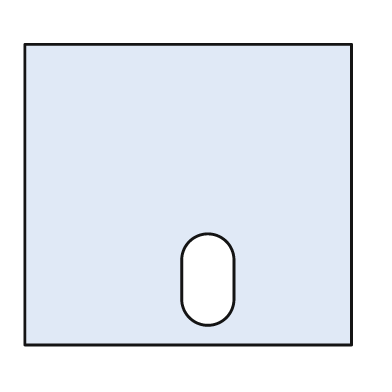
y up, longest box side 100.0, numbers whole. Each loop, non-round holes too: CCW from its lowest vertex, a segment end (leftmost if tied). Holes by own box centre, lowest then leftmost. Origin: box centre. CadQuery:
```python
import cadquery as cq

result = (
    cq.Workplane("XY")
    .moveTo(-50.0, -46.0)
    .lineTo(50.0, -46.0)
    .lineTo(50.0, 46.0)
    .lineTo(-50.0, 46.0)
    .close()
    .moveTo(-2.0, -32.0)
    .threePointArc((6.0, -40.0), (14.0, -32.0))
    .lineTo(14.0, -20.0)
    .threePointArc((6.0, -12.0), (-2.0, -20.0))
    .close()
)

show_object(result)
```